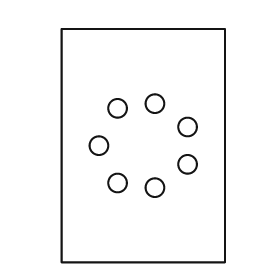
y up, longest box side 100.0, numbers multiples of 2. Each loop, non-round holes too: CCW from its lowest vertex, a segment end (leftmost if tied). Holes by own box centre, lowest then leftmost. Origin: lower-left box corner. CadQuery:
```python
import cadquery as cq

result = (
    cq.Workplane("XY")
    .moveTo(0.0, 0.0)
    .lineTo(70.0, 0.0)
    .lineTo(70.0, 100.0)
    .lineTo(0.0, 100.0)
    .close()
    .moveTo(40.0, 32.0)
    .circle(4.0)
    .moveTo(24.0, 34.0)
    .circle(4.0)
    .moveTo(54.0, 42.0)
    .circle(4.0)
    .moveTo(16.0, 50.0)
    .circle(4.0)
    .moveTo(54.0, 58.0)
    .circle(4.0)
    .moveTo(24.0, 66.0)
    .circle(4.0)
    .moveTo(40.0, 68.0)
    .circle(4.0)
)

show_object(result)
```